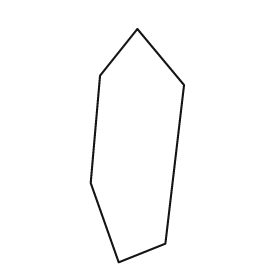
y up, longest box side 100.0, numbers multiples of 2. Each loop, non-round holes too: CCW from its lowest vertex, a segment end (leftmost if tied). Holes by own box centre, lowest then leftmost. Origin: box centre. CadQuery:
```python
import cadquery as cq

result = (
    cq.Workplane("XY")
    .moveTo(-8.0, -50.0)
    .lineTo(12.0, -42.0)
    .lineTo(20.0, 26.0)
    .lineTo(0.0, 50.0)
    .lineTo(-16.0, 30.0)
    .lineTo(-20.0, -16.0)
    .close()
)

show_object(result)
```